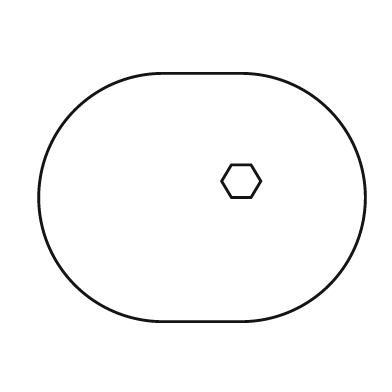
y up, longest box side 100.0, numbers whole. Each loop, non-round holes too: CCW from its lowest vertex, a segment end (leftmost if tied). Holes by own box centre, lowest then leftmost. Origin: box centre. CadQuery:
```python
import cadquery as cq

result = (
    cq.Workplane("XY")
    .moveTo(-12.0, -38.0)
    .lineTo(12.0, -38.0)
    .threePointArc((50.0, 0.0), (12.0, 38.0))
    .lineTo(-12.0, 38.0)
    .threePointArc((-50.0, 0.0), (-12.0, -38.0))
    .close()
    .moveTo(9.0, 0.0)
    .lineTo(15.0, 0.0)
    .lineTo(18.0, 5.0)
    .lineTo(15.0, 10.0)
    .lineTo(9.0, 10.0)
    .lineTo(6.0, 5.0)
    .close()
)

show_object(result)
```